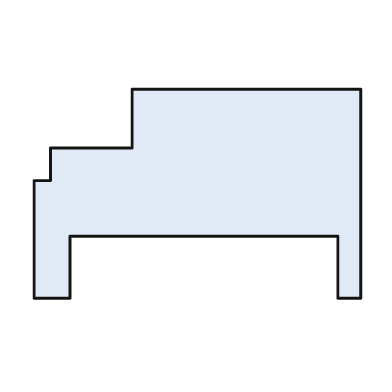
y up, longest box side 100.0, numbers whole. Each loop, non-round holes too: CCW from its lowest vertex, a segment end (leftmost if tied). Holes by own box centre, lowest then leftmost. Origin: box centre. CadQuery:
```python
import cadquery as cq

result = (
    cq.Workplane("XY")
    .moveTo(-50.0, -32.0)
    .lineTo(-39.0, -32.0)
    .lineTo(-39.0, -13.0)
    .lineTo(43.0, -13.0)
    .lineTo(43.0, -32.0)
    .lineTo(50.0, -32.0)
    .lineTo(50.0, 32.0)
    .lineTo(-20.0, 32.0)
    .lineTo(-20.0, 14.0)
    .lineTo(-45.0, 14.0)
    .lineTo(-45.0, 4.0)
    .lineTo(-50.0, 4.0)
    .close()
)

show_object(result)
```